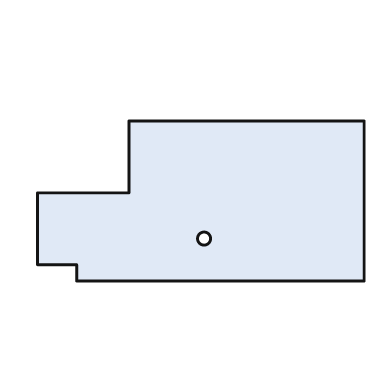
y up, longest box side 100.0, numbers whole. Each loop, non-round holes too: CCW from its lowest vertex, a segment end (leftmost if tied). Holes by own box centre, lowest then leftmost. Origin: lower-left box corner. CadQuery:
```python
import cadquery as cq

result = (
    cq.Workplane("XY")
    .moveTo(12.0, 0.0)
    .lineTo(100.0, 0.0)
    .lineTo(100.0, 49.0)
    .lineTo(28.0, 49.0)
    .lineTo(28.0, 27.0)
    .lineTo(0.0, 27.0)
    .lineTo(0.0, 5.0)
    .lineTo(12.0, 5.0)
    .close()
    .moveTo(51.0, 13.0)
    .circle(2.0)
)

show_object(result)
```